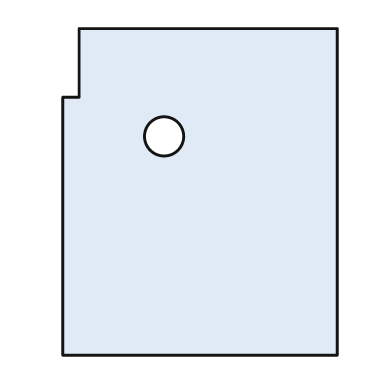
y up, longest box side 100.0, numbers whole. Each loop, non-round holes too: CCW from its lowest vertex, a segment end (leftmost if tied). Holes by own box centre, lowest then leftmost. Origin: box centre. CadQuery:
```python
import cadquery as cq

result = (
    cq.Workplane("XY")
    .moveTo(-42.0, -50.0)
    .lineTo(42.0, -50.0)
    .lineTo(42.0, 50.0)
    .lineTo(-37.0, 50.0)
    .lineTo(-37.0, 29.0)
    .lineTo(-42.0, 29.0)
    .close()
    .moveTo(-11.0, 17.0)
    .circle(6.0)
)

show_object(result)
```